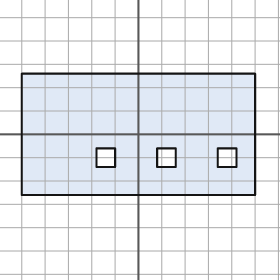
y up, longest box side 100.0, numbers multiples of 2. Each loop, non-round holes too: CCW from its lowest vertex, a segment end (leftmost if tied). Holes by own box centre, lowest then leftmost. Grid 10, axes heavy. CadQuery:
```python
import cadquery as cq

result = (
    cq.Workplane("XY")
    .moveTo(-50.0, -26.0)
    .lineTo(50.0, -26.0)
    .lineTo(50.0, 26.0)
    .lineTo(-50.0, 26.0)
    .close()
    .moveTo(-18.0, -14.0)
    .lineTo(-10.0, -14.0)
    .lineTo(-10.0, -6.0)
    .lineTo(-18.0, -6.0)
    .close()
    .moveTo(8.0, -14.0)
    .lineTo(16.0, -14.0)
    .lineTo(16.0, -6.0)
    .lineTo(8.0, -6.0)
    .close()
    .moveTo(34.0, -14.0)
    .lineTo(42.0, -14.0)
    .lineTo(42.0, -6.0)
    .lineTo(34.0, -6.0)
    .close()
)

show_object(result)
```